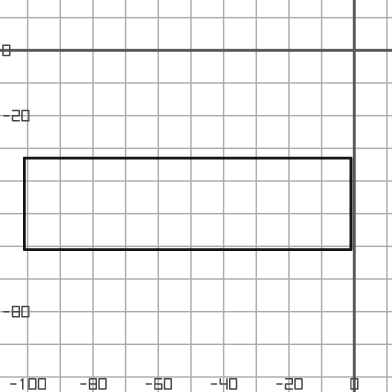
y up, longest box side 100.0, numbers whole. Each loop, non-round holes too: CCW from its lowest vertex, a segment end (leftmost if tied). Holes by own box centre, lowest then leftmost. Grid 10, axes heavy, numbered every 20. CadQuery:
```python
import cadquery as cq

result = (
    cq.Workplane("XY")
    .moveTo(-101.0, -61.0)
    .lineTo(-1.0, -61.0)
    .lineTo(-1.0, -33.0)
    .lineTo(-101.0, -33.0)
    .close()
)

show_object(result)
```